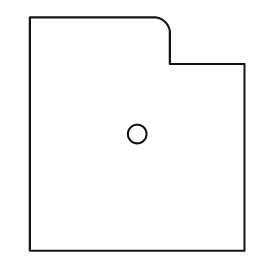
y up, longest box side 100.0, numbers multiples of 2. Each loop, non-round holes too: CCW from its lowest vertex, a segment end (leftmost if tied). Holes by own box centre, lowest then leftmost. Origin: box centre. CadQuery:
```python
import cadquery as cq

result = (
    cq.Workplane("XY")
    .moveTo(-46.0, -50.0)
    .lineTo(46.0, -50.0)
    .lineTo(46.0, 30.0)
    .lineTo(14.0, 30.0)
    .lineTo(14.0, 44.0)
    .threePointArc((12.0, 48.0), (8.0, 50.0))
    .lineTo(-46.0, 50.0)
    .close()
    .moveTo(0.0, 0.0)
    .circle(4.0)
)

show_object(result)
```